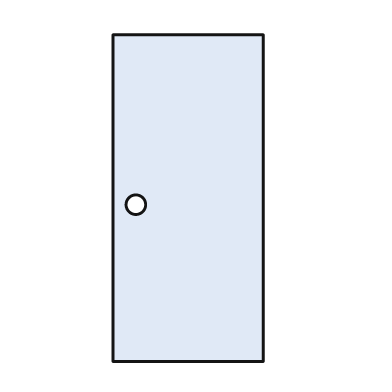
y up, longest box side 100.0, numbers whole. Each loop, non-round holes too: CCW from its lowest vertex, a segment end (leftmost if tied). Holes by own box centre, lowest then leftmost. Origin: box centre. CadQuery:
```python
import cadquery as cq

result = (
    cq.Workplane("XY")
    .moveTo(-23.0, -50.0)
    .lineTo(23.0, -50.0)
    .lineTo(23.0, 50.0)
    .lineTo(-23.0, 50.0)
    .close()
    .moveTo(-16.0, -2.0)
    .circle(3.0)
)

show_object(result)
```